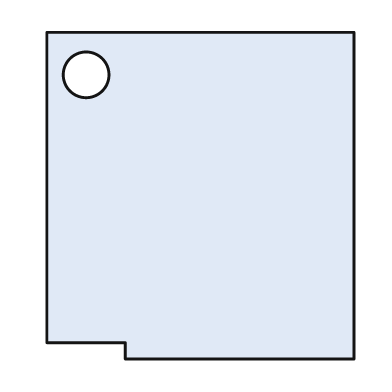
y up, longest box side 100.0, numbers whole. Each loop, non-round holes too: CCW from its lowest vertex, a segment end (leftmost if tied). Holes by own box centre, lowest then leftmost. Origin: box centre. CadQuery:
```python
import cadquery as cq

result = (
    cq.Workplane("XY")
    .moveTo(-23.0, -50.0)
    .lineTo(47.0, -50.0)
    .lineTo(47.0, 50.0)
    .lineTo(-47.0, 50.0)
    .lineTo(-47.0, -45.0)
    .lineTo(-23.0, -45.0)
    .close()
    .moveTo(-35.0, 37.0)
    .circle(7.0)
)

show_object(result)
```